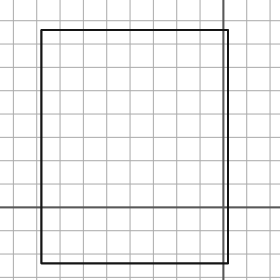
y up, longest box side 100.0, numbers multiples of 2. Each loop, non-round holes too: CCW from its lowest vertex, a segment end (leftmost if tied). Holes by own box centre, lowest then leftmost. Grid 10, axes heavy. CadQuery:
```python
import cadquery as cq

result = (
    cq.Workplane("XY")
    .moveTo(-78.0, -24.0)
    .lineTo(2.0, -24.0)
    .lineTo(2.0, 76.0)
    .lineTo(-78.0, 76.0)
    .close()
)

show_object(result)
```